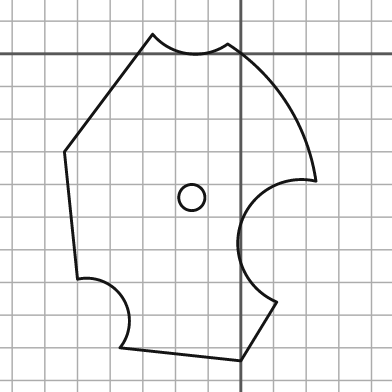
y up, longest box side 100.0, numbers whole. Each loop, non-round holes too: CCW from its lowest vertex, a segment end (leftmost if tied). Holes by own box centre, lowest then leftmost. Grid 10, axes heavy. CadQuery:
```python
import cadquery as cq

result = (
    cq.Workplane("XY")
    .moveTo(0.0, -94.0)
    .lineTo(11.0, -76.0)
    .threePointArc((0.0, -52.0), (23.0, -39.0))
    .threePointArc((14.0, -15.0), (-4.0, 3.0))
    .threePointArc((-16.0, 0.0), (-27.0, 6.0))
    .lineTo(-54.0, -30.0)
    .lineTo(-50.0, -69.0)
    .threePointArc((-36.0, -75.0), (-37.0, -90.0))
    .close()
    .moveTo(-15.0, -44.0)
    .circle(4.0)
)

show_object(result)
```